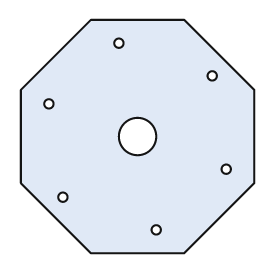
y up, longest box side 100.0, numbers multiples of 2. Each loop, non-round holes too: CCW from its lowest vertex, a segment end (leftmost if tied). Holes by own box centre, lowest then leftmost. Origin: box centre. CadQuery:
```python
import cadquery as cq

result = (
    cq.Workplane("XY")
    .moveTo(-20.0, -50.0)
    .lineTo(20.0, -50.0)
    .lineTo(50.0, -20.0)
    .lineTo(50.0, 20.0)
    .lineTo(20.0, 50.0)
    .lineTo(-20.0, 50.0)
    .lineTo(-50.0, 20.0)
    .lineTo(-50.0, -20.0)
    .close()
    .moveTo(8.0, -40.0)
    .circle(2.0)
    .moveTo(-32.0, -26.0)
    .circle(2.0)
    .moveTo(38.0, -14.0)
    .circle(2.0)
    .moveTo(0.0, 0.0)
    .circle(8.0)
    .moveTo(-38.0, 14.0)
    .circle(2.0)
    .moveTo(32.0, 26.0)
    .circle(2.0)
    .moveTo(-8.0, 40.0)
    .circle(2.0)
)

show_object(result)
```